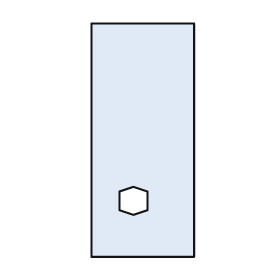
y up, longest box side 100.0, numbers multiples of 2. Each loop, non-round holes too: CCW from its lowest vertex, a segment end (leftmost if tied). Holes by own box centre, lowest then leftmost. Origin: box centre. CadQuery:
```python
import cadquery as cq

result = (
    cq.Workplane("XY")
    .moveTo(-22.0, -50.0)
    .lineTo(22.0, -50.0)
    .lineTo(22.0, 50.0)
    .lineTo(-22.0, 50.0)
    .close()
    .moveTo(-4.0, -32.0)
    .lineTo(2.0, -30.0)
    .lineTo(2.0, -22.0)
    .lineTo(-4.0, -20.0)
    .lineTo(-10.0, -22.0)
    .lineTo(-10.0, -30.0)
    .close()
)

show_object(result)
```